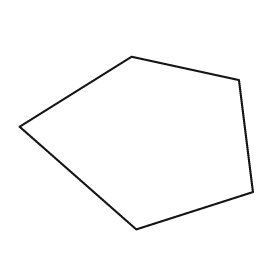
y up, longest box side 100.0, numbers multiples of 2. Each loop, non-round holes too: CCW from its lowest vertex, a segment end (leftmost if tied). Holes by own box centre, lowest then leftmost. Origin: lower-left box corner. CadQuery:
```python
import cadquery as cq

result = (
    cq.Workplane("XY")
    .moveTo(50.0, 0.0)
    .lineTo(100.0, 16.0)
    .lineTo(94.0, 64.0)
    .lineTo(48.0, 74.0)
    .lineTo(0.0, 44.0)
    .close()
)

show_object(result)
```